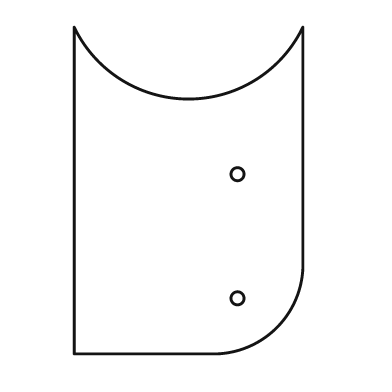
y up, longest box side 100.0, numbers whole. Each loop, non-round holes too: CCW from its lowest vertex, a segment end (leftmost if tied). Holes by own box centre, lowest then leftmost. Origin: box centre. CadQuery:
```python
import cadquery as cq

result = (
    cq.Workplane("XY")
    .moveTo(-35.0, -50.0)
    .lineTo(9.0, -50.0)
    .threePointArc((27.0, -42.0), (35.0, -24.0))
    .lineTo(35.0, 50.0)
    .threePointArc((0.0, 28.0), (-35.0, 50.0))
    .close()
    .moveTo(15.0, -33.0)
    .circle(2.0)
    .moveTo(15.0, 5.0)
    .circle(2.0)
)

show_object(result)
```